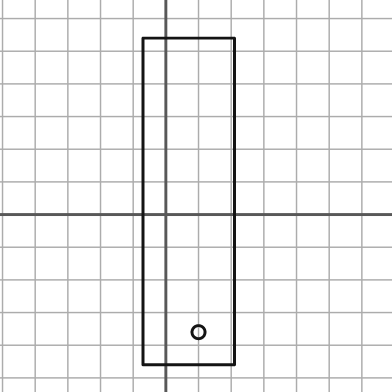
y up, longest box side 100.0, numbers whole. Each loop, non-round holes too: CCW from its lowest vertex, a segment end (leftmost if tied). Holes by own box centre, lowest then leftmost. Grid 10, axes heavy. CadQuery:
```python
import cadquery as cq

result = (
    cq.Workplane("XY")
    .moveTo(-7.0, -46.0)
    .lineTo(21.0, -46.0)
    .lineTo(21.0, 54.0)
    .lineTo(-7.0, 54.0)
    .close()
    .moveTo(10.0, -36.0)
    .circle(2.0)
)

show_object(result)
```